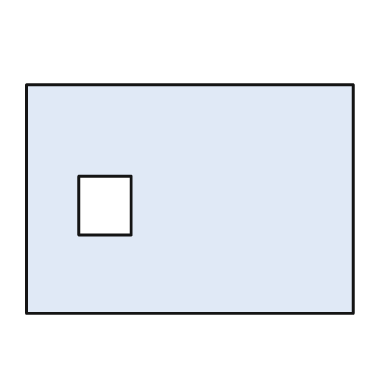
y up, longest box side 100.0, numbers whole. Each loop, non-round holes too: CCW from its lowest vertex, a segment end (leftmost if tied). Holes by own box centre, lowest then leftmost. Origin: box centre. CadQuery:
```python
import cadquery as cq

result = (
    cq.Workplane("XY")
    .moveTo(-50.0, -35.0)
    .lineTo(50.0, -35.0)
    .lineTo(50.0, 35.0)
    .lineTo(-50.0, 35.0)
    .close()
    .moveTo(-34.0, -11.0)
    .lineTo(-18.0, -11.0)
    .lineTo(-18.0, 7.0)
    .lineTo(-34.0, 7.0)
    .close()
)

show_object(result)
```